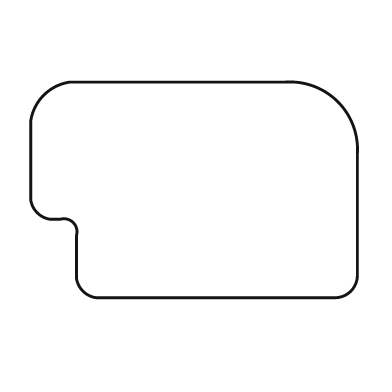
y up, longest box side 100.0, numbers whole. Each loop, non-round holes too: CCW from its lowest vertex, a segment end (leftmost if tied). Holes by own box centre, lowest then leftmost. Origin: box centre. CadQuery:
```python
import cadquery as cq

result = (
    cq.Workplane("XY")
    .moveTo(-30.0, -33.0)
    .lineTo(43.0, -33.0)
    .threePointArc((48.0, -31.0), (50.0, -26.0))
    .lineTo(50.0, 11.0)
    .threePointArc((44.0, 27.0), (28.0, 33.0))
    .lineTo(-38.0, 33.0)
    .threePointArc((-46.0, 29.0), (-50.0, 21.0))
    .lineTo(-50.0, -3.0)
    .threePointArc((-48.0, -7.0), (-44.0, -9.0))
    .lineTo(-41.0, -9.0)
    .threePointArc((-37.0, -10.0), (-36.0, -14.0))
    .lineTo(-36.0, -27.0)
    .threePointArc((-34.0, -31.0), (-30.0, -33.0))
    .close()
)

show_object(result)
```